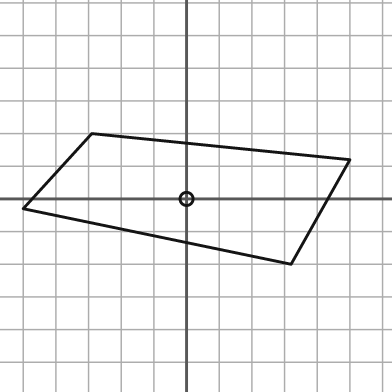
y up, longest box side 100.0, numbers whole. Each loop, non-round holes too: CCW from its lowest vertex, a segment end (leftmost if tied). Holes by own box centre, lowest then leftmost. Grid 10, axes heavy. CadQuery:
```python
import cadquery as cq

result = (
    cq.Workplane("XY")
    .moveTo(32.0, -20.0)
    .lineTo(50.0, 12.0)
    .lineTo(-29.0, 20.0)
    .lineTo(-50.0, -3.0)
    .close()
    .moveTo(0.0, 0.0)
    .circle(2.0)
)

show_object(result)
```